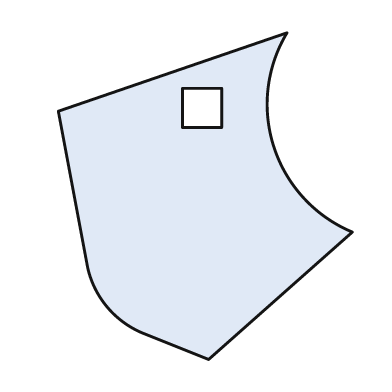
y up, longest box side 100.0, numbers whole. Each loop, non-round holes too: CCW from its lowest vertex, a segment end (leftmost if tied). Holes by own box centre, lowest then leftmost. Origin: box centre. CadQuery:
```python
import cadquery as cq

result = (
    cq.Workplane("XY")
    .moveTo(1.0, -50.0)
    .lineTo(45.0, -11.0)
    .threePointArc((21.0, 15.0), (25.0, 50.0))
    .lineTo(-45.0, 26.0)
    .lineTo(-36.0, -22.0)
    .threePointArc((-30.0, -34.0), (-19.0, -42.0))
    .close()
    .moveTo(-7.0, 21.0)
    .lineTo(5.0, 21.0)
    .lineTo(5.0, 33.0)
    .lineTo(-7.0, 33.0)
    .close()
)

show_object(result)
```